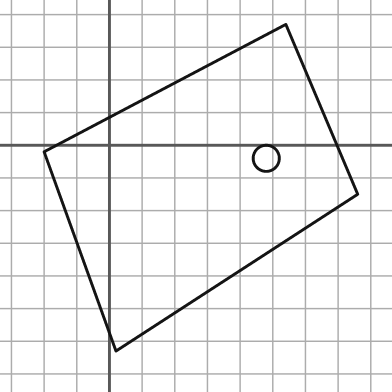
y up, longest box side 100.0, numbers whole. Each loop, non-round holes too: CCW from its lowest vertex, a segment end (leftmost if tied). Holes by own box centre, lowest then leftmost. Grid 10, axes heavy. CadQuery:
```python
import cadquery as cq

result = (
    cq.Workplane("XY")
    .moveTo(2.0, -63.0)
    .lineTo(76.0, -15.0)
    .lineTo(54.0, 37.0)
    .lineTo(-20.0, -2.0)
    .close()
    .moveTo(48.0, -4.0)
    .circle(4.0)
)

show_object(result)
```